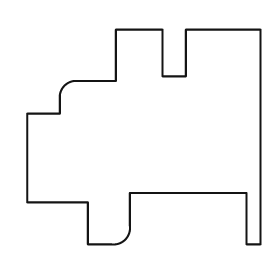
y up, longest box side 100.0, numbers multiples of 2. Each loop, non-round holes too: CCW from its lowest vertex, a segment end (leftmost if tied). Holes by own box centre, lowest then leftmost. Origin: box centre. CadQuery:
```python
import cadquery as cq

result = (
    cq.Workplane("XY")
    .moveTo(-24.0, -46.0)
    .lineTo(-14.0, -46.0)
    .threePointArc((-8.0, -44.0), (-6.0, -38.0))
    .lineTo(-6.0, -24.0)
    .lineTo(44.0, -24.0)
    .lineTo(44.0, -46.0)
    .lineTo(50.0, -46.0)
    .lineTo(50.0, 46.0)
    .lineTo(18.0, 46.0)
    .lineTo(18.0, 26.0)
    .lineTo(8.0, 26.0)
    .lineTo(8.0, 46.0)
    .lineTo(-12.0, 46.0)
    .lineTo(-12.0, 24.0)
    .lineTo(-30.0, 24.0)
    .threePointArc((-34.0, 22.0), (-36.0, 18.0))
    .lineTo(-36.0, 10.0)
    .lineTo(-50.0, 10.0)
    .lineTo(-50.0, -28.0)
    .lineTo(-24.0, -28.0)
    .close()
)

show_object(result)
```